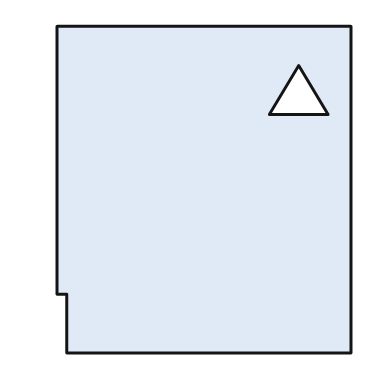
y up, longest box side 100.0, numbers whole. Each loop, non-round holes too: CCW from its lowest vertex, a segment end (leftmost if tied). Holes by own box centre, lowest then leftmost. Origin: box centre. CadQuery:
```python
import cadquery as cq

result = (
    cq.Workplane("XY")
    .moveTo(-42.0, -50.0)
    .lineTo(45.0, -50.0)
    .lineTo(45.0, 50.0)
    .lineTo(-45.0, 50.0)
    .lineTo(-45.0, -32.0)
    .lineTo(-42.0, -32.0)
    .close()
    .moveTo(20.0, 23.0)
    .lineTo(38.0, 23.0)
    .lineTo(29.0, 38.0)
    .close()
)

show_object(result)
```